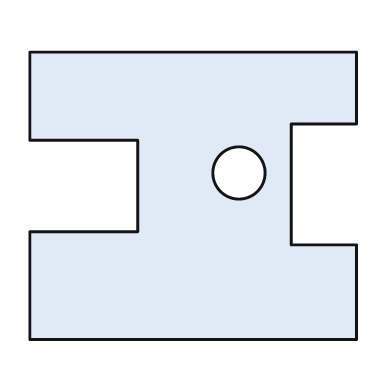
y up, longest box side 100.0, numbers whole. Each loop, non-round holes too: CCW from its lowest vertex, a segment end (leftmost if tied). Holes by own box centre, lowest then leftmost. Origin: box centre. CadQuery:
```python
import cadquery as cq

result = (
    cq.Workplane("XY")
    .moveTo(-50.0, -44.0)
    .lineTo(50.0, -44.0)
    .lineTo(50.0, -15.0)
    .lineTo(30.0, -15.0)
    .lineTo(30.0, 22.0)
    .lineTo(50.0, 22.0)
    .lineTo(50.0, 44.0)
    .lineTo(-50.0, 44.0)
    .lineTo(-50.0, 17.0)
    .lineTo(-17.0, 17.0)
    .lineTo(-17.0, -11.0)
    .lineTo(-50.0, -11.0)
    .close()
    .moveTo(14.0, 7.0)
    .circle(8.0)
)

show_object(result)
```